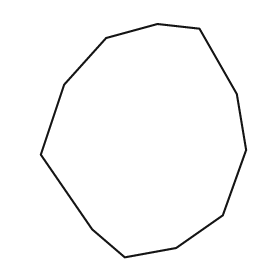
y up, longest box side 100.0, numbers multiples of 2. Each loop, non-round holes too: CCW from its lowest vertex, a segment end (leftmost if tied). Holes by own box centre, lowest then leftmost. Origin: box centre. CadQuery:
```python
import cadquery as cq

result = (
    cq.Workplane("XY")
    .moveTo(-8.0, -50.0)
    .lineTo(14.0, -46.0)
    .lineTo(34.0, -32.0)
    .lineTo(44.0, -4.0)
    .lineTo(40.0, 20.0)
    .lineTo(24.0, 48.0)
    .lineTo(6.0, 50.0)
    .lineTo(-16.0, 44.0)
    .lineTo(-34.0, 24.0)
    .lineTo(-44.0, -6.0)
    .lineTo(-22.0, -38.0)
    .close()
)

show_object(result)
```